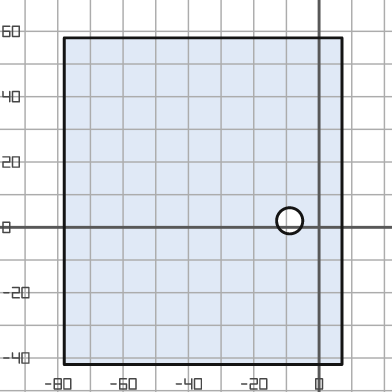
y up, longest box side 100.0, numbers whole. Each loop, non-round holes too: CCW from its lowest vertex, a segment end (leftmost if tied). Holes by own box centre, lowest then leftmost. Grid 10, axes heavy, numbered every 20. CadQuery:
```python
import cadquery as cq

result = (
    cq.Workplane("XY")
    .moveTo(-78.0, -42.0)
    .lineTo(7.0, -42.0)
    .lineTo(7.0, 58.0)
    .lineTo(-78.0, 58.0)
    .close()
    .moveTo(-9.0, 2.0)
    .circle(4.0)
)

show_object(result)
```